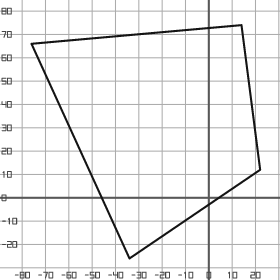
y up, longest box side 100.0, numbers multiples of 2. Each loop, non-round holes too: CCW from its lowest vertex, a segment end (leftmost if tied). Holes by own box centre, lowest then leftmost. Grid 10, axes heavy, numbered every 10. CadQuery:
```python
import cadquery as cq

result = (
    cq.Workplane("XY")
    .moveTo(-34.0, -26.0)
    .lineTo(22.0, 12.0)
    .lineTo(14.0, 74.0)
    .lineTo(-76.0, 66.0)
    .close()
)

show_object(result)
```